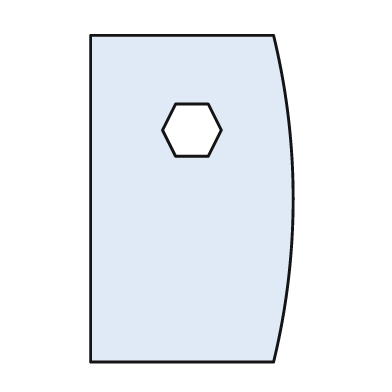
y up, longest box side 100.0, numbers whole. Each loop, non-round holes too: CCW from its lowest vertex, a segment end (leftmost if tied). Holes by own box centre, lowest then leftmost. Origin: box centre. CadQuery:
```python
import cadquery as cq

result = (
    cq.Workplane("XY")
    .moveTo(-31.0, -50.0)
    .lineTo(25.0, -50.0)
    .threePointArc((31.0, 0.0), (25.0, 50.0))
    .lineTo(-31.0, 50.0)
    .close()
    .moveTo(-5.0, 13.0)
    .lineTo(5.0, 13.0)
    .lineTo(9.0, 21.0)
    .lineTo(5.0, 29.0)
    .lineTo(-5.0, 29.0)
    .lineTo(-9.0, 21.0)
    .close()
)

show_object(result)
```